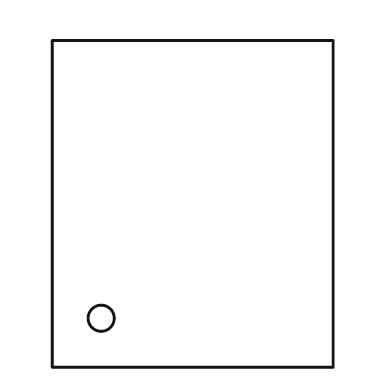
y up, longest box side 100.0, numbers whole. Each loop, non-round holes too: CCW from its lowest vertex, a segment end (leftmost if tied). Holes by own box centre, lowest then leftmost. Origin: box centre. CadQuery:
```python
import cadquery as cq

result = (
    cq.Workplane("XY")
    .moveTo(-43.0, -50.0)
    .lineTo(43.0, -50.0)
    .lineTo(43.0, 50.0)
    .lineTo(-43.0, 50.0)
    .close()
    .moveTo(-28.0, -35.0)
    .circle(4.0)
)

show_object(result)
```